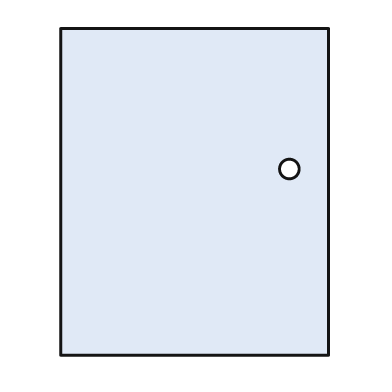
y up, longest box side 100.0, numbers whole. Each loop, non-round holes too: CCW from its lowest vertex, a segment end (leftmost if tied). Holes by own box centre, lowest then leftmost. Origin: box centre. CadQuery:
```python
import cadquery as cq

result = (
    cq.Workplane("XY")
    .moveTo(-41.0, -50.0)
    .lineTo(41.0, -50.0)
    .lineTo(41.0, 50.0)
    .lineTo(-41.0, 50.0)
    .close()
    .moveTo(29.0, 7.0)
    .circle(3.0)
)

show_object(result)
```